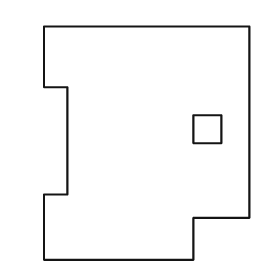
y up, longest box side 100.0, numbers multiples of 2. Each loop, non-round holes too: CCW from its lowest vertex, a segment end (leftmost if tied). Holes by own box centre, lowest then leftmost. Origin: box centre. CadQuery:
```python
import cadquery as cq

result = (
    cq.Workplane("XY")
    .moveTo(-44.0, -50.0)
    .lineTo(20.0, -50.0)
    .lineTo(20.0, -32.0)
    .lineTo(44.0, -32.0)
    .lineTo(44.0, 50.0)
    .lineTo(-44.0, 50.0)
    .lineTo(-44.0, 24.0)
    .lineTo(-34.0, 24.0)
    .lineTo(-34.0, -22.0)
    .lineTo(-44.0, -22.0)
    .close()
    .moveTo(20.0, 0.0)
    .lineTo(32.0, 0.0)
    .lineTo(32.0, 12.0)
    .lineTo(20.0, 12.0)
    .close()
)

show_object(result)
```